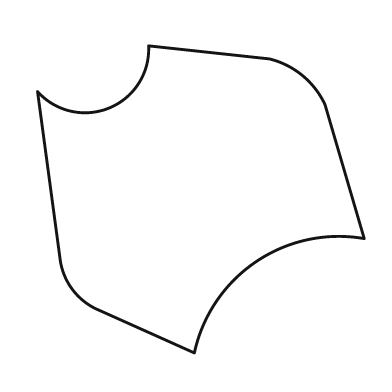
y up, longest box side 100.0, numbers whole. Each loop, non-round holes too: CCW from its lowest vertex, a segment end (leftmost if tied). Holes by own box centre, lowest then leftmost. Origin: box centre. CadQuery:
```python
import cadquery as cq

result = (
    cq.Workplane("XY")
    .moveTo(-2.0, -47.0)
    .threePointArc((17.0, -19.0), (50.0, -12.0))
    .lineTo(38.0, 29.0)
    .threePointArc((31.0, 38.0), (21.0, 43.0))
    .lineTo(-16.0, 47.0)
    .threePointArc((-28.0, 28.0), (-50.0, 33.0))
    .lineTo(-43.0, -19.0)
    .threePointArc((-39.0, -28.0), (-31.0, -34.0))
    .close()
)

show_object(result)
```